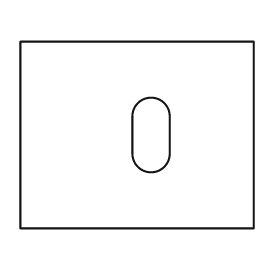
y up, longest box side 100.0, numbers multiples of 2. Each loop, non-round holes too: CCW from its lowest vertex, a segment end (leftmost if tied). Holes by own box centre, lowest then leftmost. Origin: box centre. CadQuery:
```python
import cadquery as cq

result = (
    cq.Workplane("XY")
    .moveTo(-50.0, -40.0)
    .lineTo(50.0, -40.0)
    .lineTo(50.0, 40.0)
    .lineTo(-50.0, 40.0)
    .close()
    .moveTo(-2.0, -8.0)
    .threePointArc((6.0, -16.0), (14.0, -8.0))
    .lineTo(14.0, 8.0)
    .threePointArc((6.0, 16.0), (-2.0, 8.0))
    .close()
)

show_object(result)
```